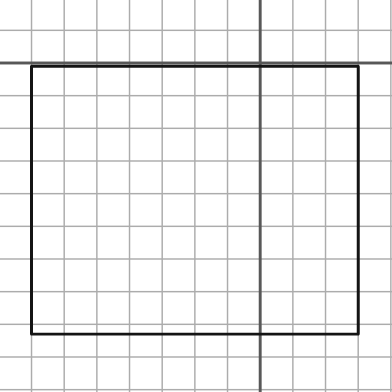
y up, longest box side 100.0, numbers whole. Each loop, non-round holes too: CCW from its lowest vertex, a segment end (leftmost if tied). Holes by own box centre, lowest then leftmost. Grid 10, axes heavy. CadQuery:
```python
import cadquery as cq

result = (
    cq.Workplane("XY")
    .moveTo(-70.0, -83.0)
    .lineTo(30.0, -83.0)
    .lineTo(30.0, -1.0)
    .lineTo(-70.0, -1.0)
    .close()
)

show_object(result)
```